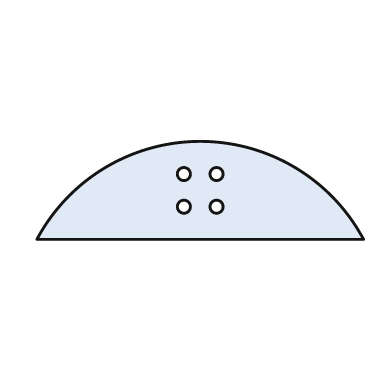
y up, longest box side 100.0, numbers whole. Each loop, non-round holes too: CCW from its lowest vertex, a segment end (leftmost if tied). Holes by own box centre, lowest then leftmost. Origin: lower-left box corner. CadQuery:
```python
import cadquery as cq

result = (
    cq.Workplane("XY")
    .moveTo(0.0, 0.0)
    .lineTo(100.0, 0.0)
    .threePointArc((50.0, 30.0), (0.0, 0.0))
    .close()
    .moveTo(45.0, 10.0)
    .circle(2.0)
    .moveTo(55.0, 10.0)
    .circle(2.0)
    .moveTo(45.0, 20.0)
    .circle(2.0)
    .moveTo(55.0, 20.0)
    .circle(2.0)
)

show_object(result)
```